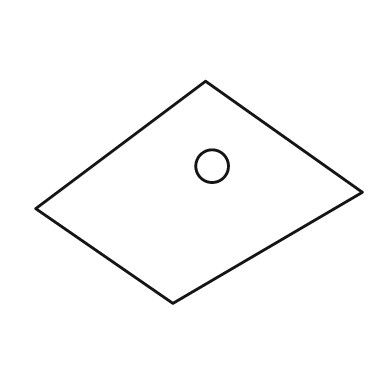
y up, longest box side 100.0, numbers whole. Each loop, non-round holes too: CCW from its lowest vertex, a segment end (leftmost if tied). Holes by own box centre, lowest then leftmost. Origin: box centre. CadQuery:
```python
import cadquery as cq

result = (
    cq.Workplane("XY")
    .moveTo(-8.0, -34.0)
    .lineTo(50.0, 0.0)
    .lineTo(2.0, 34.0)
    .lineTo(-50.0, -5.0)
    .close()
    .moveTo(4.0, 8.0)
    .circle(5.0)
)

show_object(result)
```